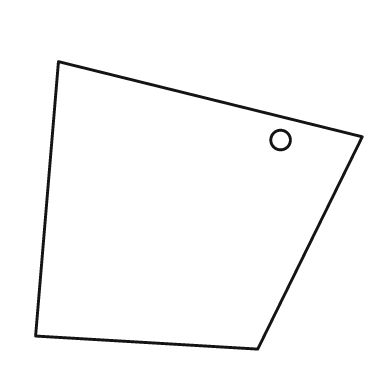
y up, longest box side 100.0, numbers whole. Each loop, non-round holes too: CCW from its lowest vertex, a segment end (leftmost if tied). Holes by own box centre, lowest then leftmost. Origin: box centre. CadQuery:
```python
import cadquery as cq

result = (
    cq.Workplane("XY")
    .moveTo(18.0, -44.0)
    .lineTo(50.0, 21.0)
    .lineTo(-43.0, 44.0)
    .lineTo(-50.0, -40.0)
    .close()
    .moveTo(25.0, 20.0)
    .circle(3.0)
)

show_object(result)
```